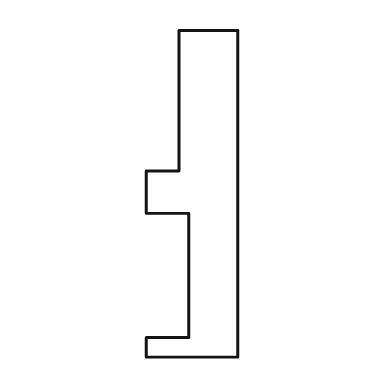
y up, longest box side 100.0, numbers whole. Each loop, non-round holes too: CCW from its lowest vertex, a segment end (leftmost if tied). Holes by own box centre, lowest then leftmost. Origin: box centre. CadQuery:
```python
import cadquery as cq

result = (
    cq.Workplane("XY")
    .moveTo(-14.0, -50.0)
    .lineTo(14.0, -50.0)
    .lineTo(14.0, 50.0)
    .lineTo(-4.0, 50.0)
    .lineTo(-4.0, 7.0)
    .lineTo(-14.0, 7.0)
    .lineTo(-14.0, -6.0)
    .lineTo(-1.0, -6.0)
    .lineTo(-1.0, -44.0)
    .lineTo(-14.0, -44.0)
    .close()
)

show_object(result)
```